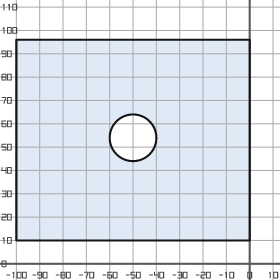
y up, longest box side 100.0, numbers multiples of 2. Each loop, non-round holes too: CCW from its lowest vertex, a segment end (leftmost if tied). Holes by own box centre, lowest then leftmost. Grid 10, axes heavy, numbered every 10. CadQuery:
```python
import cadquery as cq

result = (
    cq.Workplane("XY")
    .moveTo(-100.0, 10.0)
    .lineTo(0.0, 10.0)
    .lineTo(0.0, 96.0)
    .lineTo(-100.0, 96.0)
    .close()
    .moveTo(-50.0, 54.0)
    .circle(10.0)
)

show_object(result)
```